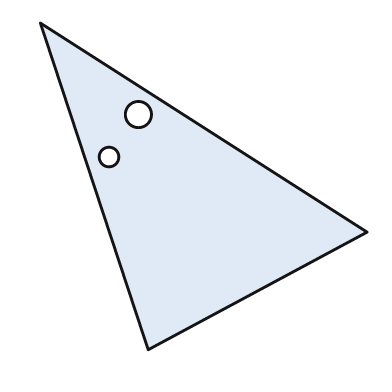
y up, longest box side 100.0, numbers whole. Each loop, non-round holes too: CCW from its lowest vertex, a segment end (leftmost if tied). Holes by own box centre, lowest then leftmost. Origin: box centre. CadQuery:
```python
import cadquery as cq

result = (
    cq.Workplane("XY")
    .moveTo(-17.0, -50.0)
    .lineTo(50.0, -14.0)
    .lineTo(-50.0, 50.0)
    .close()
    .moveTo(-29.0, 9.0)
    .circle(3.0)
    .moveTo(-20.0, 22.0)
    .circle(4.0)
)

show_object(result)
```